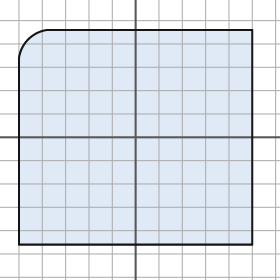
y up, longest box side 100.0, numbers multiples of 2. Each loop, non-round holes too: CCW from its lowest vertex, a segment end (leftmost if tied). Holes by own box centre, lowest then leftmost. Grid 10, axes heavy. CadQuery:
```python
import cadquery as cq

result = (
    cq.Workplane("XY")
    .moveTo(-50.0, -46.0)
    .lineTo(50.0, -46.0)
    .lineTo(50.0, 46.0)
    .lineTo(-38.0, 46.0)
    .threePointArc((-46.0, 42.0), (-50.0, 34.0))
    .close()
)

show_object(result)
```